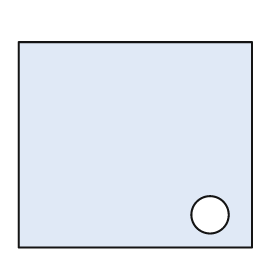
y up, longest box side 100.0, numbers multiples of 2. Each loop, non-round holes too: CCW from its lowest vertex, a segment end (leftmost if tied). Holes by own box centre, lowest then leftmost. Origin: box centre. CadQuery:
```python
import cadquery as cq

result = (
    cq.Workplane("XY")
    .moveTo(-50.0, -44.0)
    .lineTo(50.0, -44.0)
    .lineTo(50.0, 44.0)
    .lineTo(-50.0, 44.0)
    .close()
    .moveTo(32.0, -30.0)
    .circle(8.0)
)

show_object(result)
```